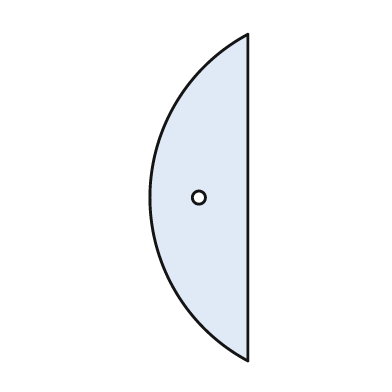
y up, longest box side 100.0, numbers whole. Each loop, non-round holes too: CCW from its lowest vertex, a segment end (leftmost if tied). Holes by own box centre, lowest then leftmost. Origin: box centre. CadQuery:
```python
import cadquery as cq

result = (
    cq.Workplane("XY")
    .moveTo(15.0, -50.0)
    .lineTo(15.0, 50.0)
    .threePointArc((-15.0, 0.0), (15.0, -50.0))
    .close()
    .moveTo(0.0, 0.0)
    .circle(2.0)
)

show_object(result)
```